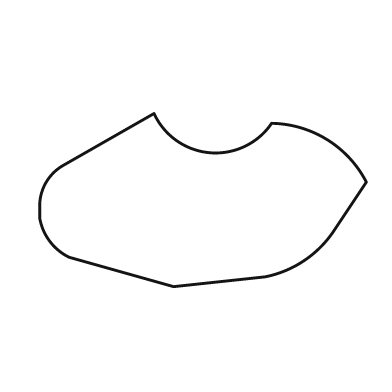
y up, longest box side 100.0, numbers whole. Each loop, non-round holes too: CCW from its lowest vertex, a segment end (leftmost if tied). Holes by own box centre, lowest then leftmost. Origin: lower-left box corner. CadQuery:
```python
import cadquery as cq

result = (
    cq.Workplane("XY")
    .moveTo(41.0, 0.0)
    .lineTo(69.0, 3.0)
    .threePointArc((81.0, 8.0), (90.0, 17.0))
    .lineTo(100.0, 32.0)
    .threePointArc((88.0, 45.0), (71.0, 50.0))
    .threePointArc((52.0, 41.0), (35.0, 53.0))
    .lineTo(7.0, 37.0)
    .threePointArc((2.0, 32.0), (0.0, 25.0))
    .lineTo(0.0, 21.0)
    .threePointArc((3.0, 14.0), (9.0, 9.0))
    .close()
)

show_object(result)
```